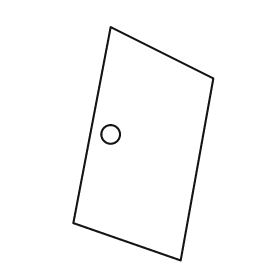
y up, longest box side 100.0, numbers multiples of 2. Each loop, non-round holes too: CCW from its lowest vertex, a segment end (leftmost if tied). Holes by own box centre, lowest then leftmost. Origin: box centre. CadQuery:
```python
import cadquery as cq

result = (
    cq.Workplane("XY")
    .moveTo(16.0, -50.0)
    .lineTo(30.0, 28.0)
    .lineTo(-14.0, 50.0)
    .lineTo(-30.0, -34.0)
    .close()
    .moveTo(-14.0, 4.0)
    .circle(4.0)
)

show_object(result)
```